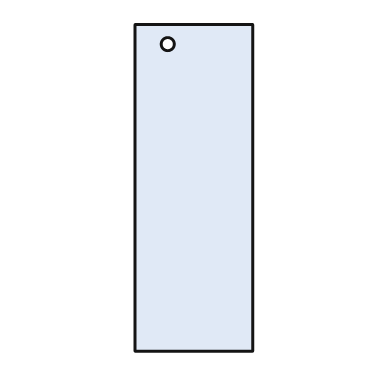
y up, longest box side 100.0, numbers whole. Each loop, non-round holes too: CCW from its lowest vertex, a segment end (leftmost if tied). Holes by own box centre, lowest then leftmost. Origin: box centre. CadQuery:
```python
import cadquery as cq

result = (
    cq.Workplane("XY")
    .moveTo(-18.0, -50.0)
    .lineTo(18.0, -50.0)
    .lineTo(18.0, 50.0)
    .lineTo(-18.0, 50.0)
    .close()
    .moveTo(-8.0, 44.0)
    .circle(2.0)
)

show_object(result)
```